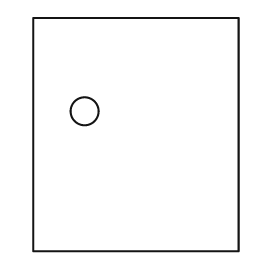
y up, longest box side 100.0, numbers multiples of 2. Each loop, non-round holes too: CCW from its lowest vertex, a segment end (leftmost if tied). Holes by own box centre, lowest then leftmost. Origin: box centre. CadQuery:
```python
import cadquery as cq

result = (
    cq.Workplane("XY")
    .moveTo(-44.0, -50.0)
    .lineTo(44.0, -50.0)
    .lineTo(44.0, 50.0)
    .lineTo(-44.0, 50.0)
    .close()
    .moveTo(-22.0, 10.0)
    .circle(6.0)
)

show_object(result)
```